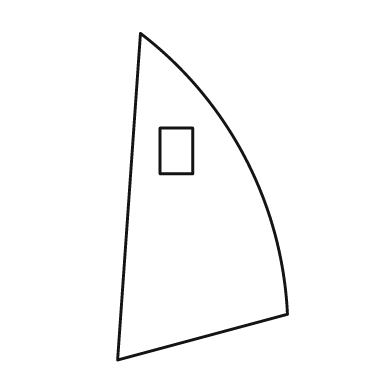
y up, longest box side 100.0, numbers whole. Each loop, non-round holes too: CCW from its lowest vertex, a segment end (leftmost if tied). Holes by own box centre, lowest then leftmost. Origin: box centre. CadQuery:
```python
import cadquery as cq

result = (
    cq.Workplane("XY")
    .moveTo(-26.0, -50.0)
    .lineTo(26.0, -36.0)
    .threePointArc((13.0, 12.0), (-19.0, 50.0))
    .close()
    .moveTo(-13.0, 7.0)
    .lineTo(-3.0, 7.0)
    .lineTo(-3.0, 21.0)
    .lineTo(-13.0, 21.0)
    .close()
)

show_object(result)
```